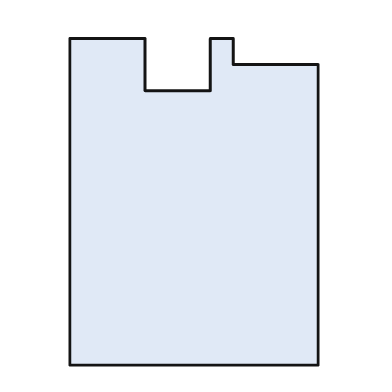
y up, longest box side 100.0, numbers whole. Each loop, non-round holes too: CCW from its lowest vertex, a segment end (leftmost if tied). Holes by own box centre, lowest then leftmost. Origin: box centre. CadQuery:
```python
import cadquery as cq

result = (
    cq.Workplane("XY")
    .moveTo(-38.0, -50.0)
    .lineTo(38.0, -50.0)
    .lineTo(38.0, 42.0)
    .lineTo(12.0, 42.0)
    .lineTo(12.0, 50.0)
    .lineTo(5.0, 50.0)
    .lineTo(5.0, 34.0)
    .lineTo(-15.0, 34.0)
    .lineTo(-15.0, 50.0)
    .lineTo(-38.0, 50.0)
    .close()
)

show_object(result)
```